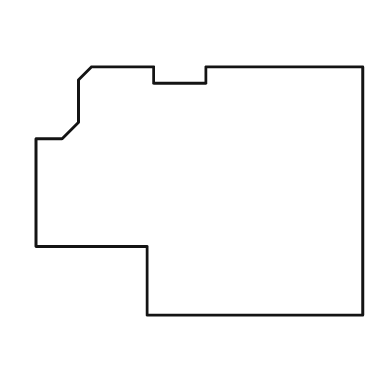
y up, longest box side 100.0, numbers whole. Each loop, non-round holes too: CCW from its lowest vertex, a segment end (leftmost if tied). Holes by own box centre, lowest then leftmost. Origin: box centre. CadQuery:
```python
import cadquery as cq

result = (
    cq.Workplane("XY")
    .moveTo(-16.0, -38.0)
    .lineTo(50.0, -38.0)
    .lineTo(50.0, 38.0)
    .lineTo(2.0, 38.0)
    .lineTo(2.0, 33.0)
    .lineTo(-14.0, 33.0)
    .lineTo(-14.0, 38.0)
    .lineTo(-33.0, 38.0)
    .lineTo(-37.0, 34.0)
    .lineTo(-37.0, 21.0)
    .lineTo(-42.0, 16.0)
    .lineTo(-50.0, 16.0)
    .lineTo(-50.0, -17.0)
    .lineTo(-16.0, -17.0)
    .close()
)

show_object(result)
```